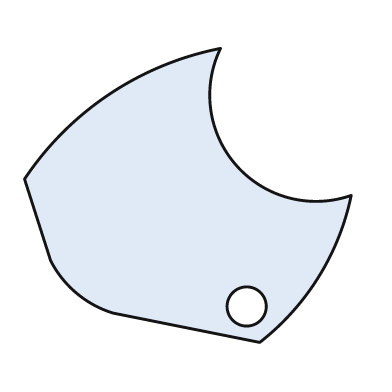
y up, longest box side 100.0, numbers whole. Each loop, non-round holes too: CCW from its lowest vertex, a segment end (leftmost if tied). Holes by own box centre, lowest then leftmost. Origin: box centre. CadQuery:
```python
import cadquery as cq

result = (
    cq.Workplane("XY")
    .moveTo(22.0, -45.0)
    .threePointArc((40.0, -25.0), (50.0, 0.0))
    .threePointArc((15.0, 9.0), (10.0, 45.0))
    .threePointArc((-24.0, 31.0), (-50.0, 5.0))
    .lineTo(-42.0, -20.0)
    .threePointArc((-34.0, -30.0), (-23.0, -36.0))
    .close()
    .moveTo(18.0, -34.0)
    .circle(6.0)
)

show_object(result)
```